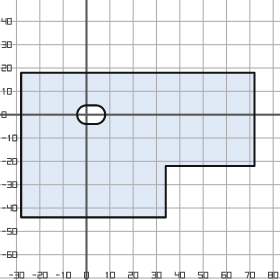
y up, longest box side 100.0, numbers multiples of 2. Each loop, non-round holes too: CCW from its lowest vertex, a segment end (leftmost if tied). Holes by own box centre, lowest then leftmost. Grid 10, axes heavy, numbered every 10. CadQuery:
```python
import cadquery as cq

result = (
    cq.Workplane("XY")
    .moveTo(-28.0, -44.0)
    .lineTo(34.0, -44.0)
    .lineTo(34.0, -22.0)
    .lineTo(72.0, -22.0)
    .lineTo(72.0, 18.0)
    .lineTo(-28.0, 18.0)
    .close()
    .moveTo(0.0, -4.0)
    .lineTo(4.0, -4.0)
    .threePointArc((8.0, 0.0), (4.0, 4.0))
    .lineTo(0.0, 4.0)
    .threePointArc((-4.0, 0.0), (0.0, -4.0))
    .close()
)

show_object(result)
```